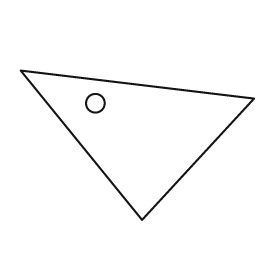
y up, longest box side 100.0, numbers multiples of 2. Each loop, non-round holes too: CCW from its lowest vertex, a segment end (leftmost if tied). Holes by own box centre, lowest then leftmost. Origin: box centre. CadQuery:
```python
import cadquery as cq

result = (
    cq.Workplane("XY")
    .moveTo(2.0, -32.0)
    .lineTo(50.0, 20.0)
    .lineTo(-50.0, 32.0)
    .close()
    .moveTo(-18.0, 18.0)
    .circle(4.0)
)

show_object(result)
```